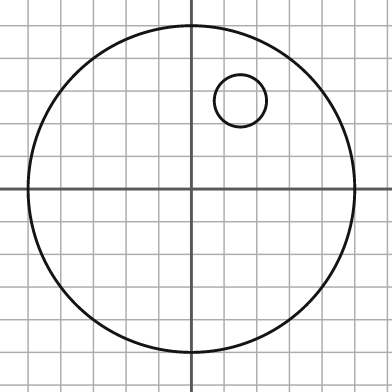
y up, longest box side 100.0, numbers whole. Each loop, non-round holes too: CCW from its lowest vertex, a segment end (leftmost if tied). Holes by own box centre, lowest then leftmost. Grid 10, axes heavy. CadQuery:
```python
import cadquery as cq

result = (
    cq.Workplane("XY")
    .moveTo(0.0, 0.0)
    .circle(50.0)
    .moveTo(15.0, 27.0)
    .circle(8.0)
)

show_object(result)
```